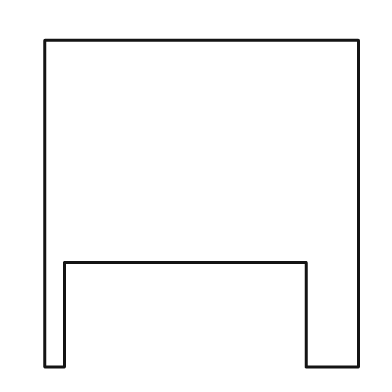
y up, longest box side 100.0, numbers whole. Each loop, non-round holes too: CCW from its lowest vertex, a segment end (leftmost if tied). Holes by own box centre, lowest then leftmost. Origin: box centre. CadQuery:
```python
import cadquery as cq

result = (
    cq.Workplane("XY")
    .moveTo(-48.0, -50.0)
    .lineTo(-42.0, -50.0)
    .lineTo(-42.0, -18.0)
    .lineTo(32.0, -18.0)
    .lineTo(32.0, -50.0)
    .lineTo(48.0, -50.0)
    .lineTo(48.0, 50.0)
    .lineTo(-48.0, 50.0)
    .close()
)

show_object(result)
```